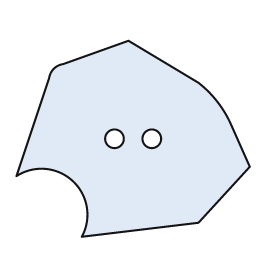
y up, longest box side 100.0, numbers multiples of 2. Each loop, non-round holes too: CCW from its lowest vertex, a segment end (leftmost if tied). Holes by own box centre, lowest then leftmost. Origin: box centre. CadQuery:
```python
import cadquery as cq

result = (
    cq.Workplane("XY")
    .moveTo(-22.0, -42.0)
    .lineTo(28.0, -36.0)
    .lineTo(50.0, -12.0)
    .lineTo(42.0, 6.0)
    .threePointArc((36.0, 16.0), (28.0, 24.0))
    .lineTo(-2.0, 42.0)
    .lineTo(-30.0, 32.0)
    .threePointArc((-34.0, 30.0), (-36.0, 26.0))
    .lineTo(-50.0, -16.0)
    .threePointArc((-26.0, -18.0), (-22.0, -42.0))
    .close()
    .moveTo(-8.0, 0.0)
    .circle(4.0)
    .moveTo(8.0, 0.0)
    .circle(4.0)
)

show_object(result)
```